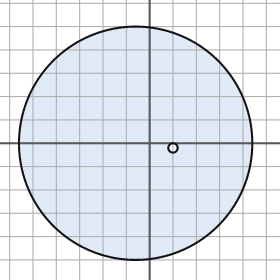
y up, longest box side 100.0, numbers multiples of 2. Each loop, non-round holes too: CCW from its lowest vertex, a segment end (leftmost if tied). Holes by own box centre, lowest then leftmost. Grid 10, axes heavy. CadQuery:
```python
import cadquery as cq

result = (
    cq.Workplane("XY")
    .moveTo(-6.0, 0.0)
    .circle(50.0)
    .moveTo(10.0, -2.0)
    .circle(2.0)
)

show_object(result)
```